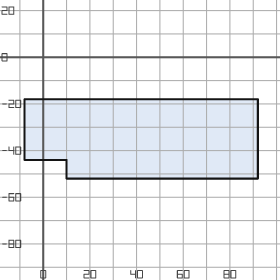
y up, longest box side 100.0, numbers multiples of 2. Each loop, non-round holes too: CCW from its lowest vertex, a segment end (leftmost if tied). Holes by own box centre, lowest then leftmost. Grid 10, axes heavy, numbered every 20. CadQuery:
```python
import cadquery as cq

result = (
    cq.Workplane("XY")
    .moveTo(10.0, -52.0)
    .lineTo(92.0, -52.0)
    .lineTo(92.0, -18.0)
    .lineTo(-8.0, -18.0)
    .lineTo(-8.0, -44.0)
    .lineTo(10.0, -44.0)
    .close()
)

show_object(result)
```